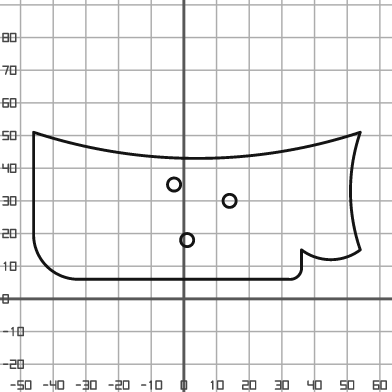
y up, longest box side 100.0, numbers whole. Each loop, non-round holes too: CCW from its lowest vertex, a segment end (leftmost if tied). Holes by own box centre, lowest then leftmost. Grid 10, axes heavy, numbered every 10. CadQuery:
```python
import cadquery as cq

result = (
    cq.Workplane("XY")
    .moveTo(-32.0, 6.0)
    .lineTo(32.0, 6.0)
    .threePointArc((35.0, 7.0), (36.0, 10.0))
    .lineTo(36.0, 15.0)
    .threePointArc((45.0, 12.0), (54.0, 15.0))
    .threePointArc((51.0, 33.0), (54.0, 51.0))
    .threePointArc((4.0, 43.0), (-46.0, 51.0))
    .lineTo(-46.0, 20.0)
    .threePointArc((-42.0, 10.0), (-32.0, 6.0))
    .close()
    .moveTo(1.0, 18.0)
    .circle(2.0)
    .moveTo(14.0, 30.0)
    .circle(2.0)
    .moveTo(-3.0, 35.0)
    .circle(2.0)
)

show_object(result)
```